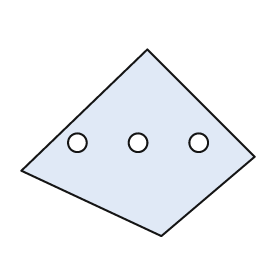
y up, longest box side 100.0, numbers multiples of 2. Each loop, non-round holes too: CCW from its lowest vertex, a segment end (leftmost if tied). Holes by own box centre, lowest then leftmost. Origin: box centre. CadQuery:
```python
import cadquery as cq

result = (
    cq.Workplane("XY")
    .moveTo(10.0, -40.0)
    .lineTo(50.0, -6.0)
    .lineTo(4.0, 40.0)
    .lineTo(-50.0, -12.0)
    .close()
    .moveTo(-26.0, 0.0)
    .circle(4.0)
    .moveTo(0.0, 0.0)
    .circle(4.0)
    .moveTo(26.0, 0.0)
    .circle(4.0)
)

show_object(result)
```